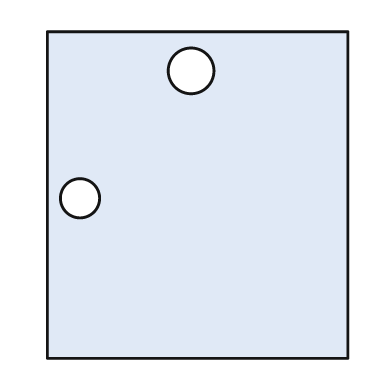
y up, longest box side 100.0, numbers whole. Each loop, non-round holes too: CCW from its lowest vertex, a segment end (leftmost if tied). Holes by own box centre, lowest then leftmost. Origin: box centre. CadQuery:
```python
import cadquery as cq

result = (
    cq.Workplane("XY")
    .moveTo(-46.0, -50.0)
    .lineTo(46.0, -50.0)
    .lineTo(46.0, 50.0)
    .lineTo(-46.0, 50.0)
    .close()
    .moveTo(-36.0, -1.0)
    .circle(6.0)
    .moveTo(-2.0, 38.0)
    .circle(7.0)
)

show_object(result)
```